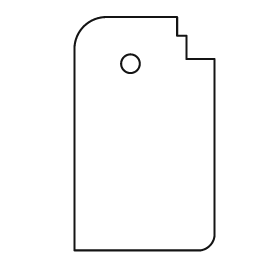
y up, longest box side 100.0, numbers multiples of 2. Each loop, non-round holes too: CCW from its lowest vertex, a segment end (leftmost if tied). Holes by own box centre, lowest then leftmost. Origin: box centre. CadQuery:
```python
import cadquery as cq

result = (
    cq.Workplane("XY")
    .moveTo(-30.0, -50.0)
    .lineTo(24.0, -50.0)
    .threePointArc((28.0, -48.0), (30.0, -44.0))
    .lineTo(30.0, 32.0)
    .lineTo(18.0, 32.0)
    .lineTo(18.0, 42.0)
    .lineTo(14.0, 42.0)
    .lineTo(14.0, 50.0)
    .lineTo(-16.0, 50.0)
    .threePointArc((-26.0, 46.0), (-30.0, 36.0))
    .close()
    .moveTo(-6.0, 30.0)
    .circle(4.0)
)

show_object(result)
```